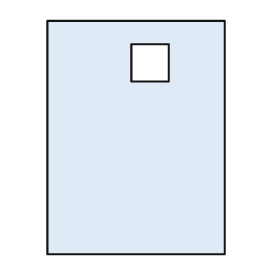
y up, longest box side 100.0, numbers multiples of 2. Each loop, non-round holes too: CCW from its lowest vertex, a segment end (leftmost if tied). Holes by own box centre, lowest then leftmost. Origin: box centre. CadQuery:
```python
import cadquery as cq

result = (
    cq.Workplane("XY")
    .moveTo(-38.0, -50.0)
    .lineTo(38.0, -50.0)
    .lineTo(38.0, 50.0)
    .lineTo(-38.0, 50.0)
    .close()
    .moveTo(-2.0, 24.0)
    .lineTo(14.0, 24.0)
    .lineTo(14.0, 40.0)
    .lineTo(-2.0, 40.0)
    .close()
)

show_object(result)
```